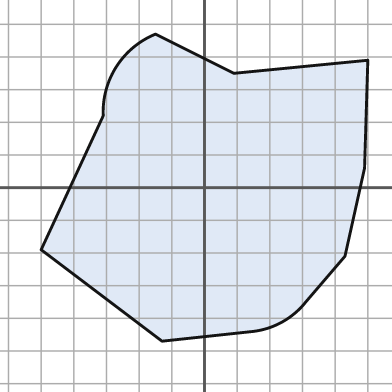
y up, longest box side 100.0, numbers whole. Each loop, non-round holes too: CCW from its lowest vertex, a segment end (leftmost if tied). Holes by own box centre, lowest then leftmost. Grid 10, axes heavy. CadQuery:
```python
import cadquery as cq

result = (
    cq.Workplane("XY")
    .moveTo(-13.0, -47.0)
    .lineTo(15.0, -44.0)
    .threePointArc((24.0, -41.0), (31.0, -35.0))
    .lineTo(43.0, -21.0)
    .lineTo(49.0, 6.0)
    .lineTo(50.0, 39.0)
    .lineTo(9.0, 35.0)
    .lineTo(-15.0, 47.0)
    .threePointArc((-27.0, 37.0), (-31.0, 22.0))
    .lineTo(-50.0, -19.0)
    .close()
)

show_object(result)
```